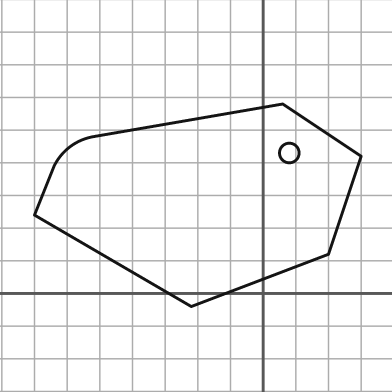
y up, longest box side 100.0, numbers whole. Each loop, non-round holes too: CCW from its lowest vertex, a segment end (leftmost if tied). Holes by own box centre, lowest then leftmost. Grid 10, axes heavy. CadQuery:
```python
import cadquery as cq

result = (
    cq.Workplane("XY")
    .moveTo(-22.0, -4.0)
    .lineTo(20.0, 12.0)
    .lineTo(30.0, 42.0)
    .lineTo(6.0, 58.0)
    .lineTo(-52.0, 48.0)
    .threePointArc((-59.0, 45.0), (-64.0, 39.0))
    .lineTo(-70.0, 24.0)
    .close()
    .moveTo(8.0, 43.0)
    .circle(3.0)
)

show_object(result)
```